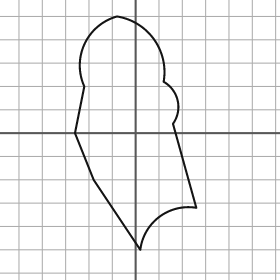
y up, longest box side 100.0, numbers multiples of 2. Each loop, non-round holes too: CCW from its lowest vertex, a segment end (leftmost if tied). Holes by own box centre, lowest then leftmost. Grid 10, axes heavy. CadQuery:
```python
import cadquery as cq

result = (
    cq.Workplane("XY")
    .moveTo(2.0, -50.0)
    .threePointArc((10.0, -36.0), (26.0, -32.0))
    .lineTo(16.0, 4.0)
    .threePointArc((18.0, 14.0), (12.0, 22.0))
    .threePointArc((8.0, 40.0), (-8.0, 50.0))
    .threePointArc((-22.0, 38.0), (-22.0, 20.0))
    .lineTo(-26.0, 0.0)
    .lineTo(-18.0, -20.0)
    .close()
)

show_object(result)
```